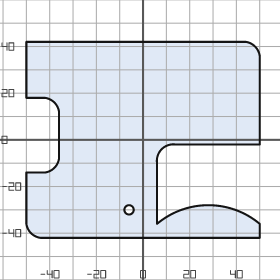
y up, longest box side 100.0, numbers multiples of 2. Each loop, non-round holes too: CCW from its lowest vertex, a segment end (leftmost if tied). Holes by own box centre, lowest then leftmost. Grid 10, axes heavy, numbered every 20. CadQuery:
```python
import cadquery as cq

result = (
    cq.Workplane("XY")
    .moveTo(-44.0, -42.0)
    .lineTo(50.0, -42.0)
    .lineTo(50.0, -36.0)
    .threePointArc((28.0, -28.0), (6.0, -36.0))
    .lineTo(6.0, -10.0)
    .threePointArc((8.0, -4.0), (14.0, -2.0))
    .lineTo(50.0, -2.0)
    .lineTo(50.0, 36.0)
    .threePointArc((48.0, 40.0), (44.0, 42.0))
    .lineTo(-50.0, 42.0)
    .lineTo(-50.0, 18.0)
    .lineTo(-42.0, 18.0)
    .threePointArc((-38.0, 16.0), (-36.0, 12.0))
    .lineTo(-36.0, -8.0)
    .threePointArc((-38.0, -12.0), (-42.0, -14.0))
    .lineTo(-50.0, -14.0)
    .lineTo(-50.0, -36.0)
    .threePointArc((-48.0, -40.0), (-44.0, -42.0))
    .close()
    .moveTo(-6.0, -30.0)
    .circle(2.0)
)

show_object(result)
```